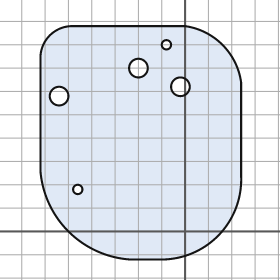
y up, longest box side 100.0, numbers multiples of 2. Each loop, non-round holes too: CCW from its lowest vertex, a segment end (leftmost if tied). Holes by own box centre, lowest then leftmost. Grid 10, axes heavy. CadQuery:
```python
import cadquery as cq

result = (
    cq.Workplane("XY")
    .moveTo(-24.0, -12.0)
    .lineTo(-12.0, -12.0)
    .threePointArc((14.0, -2.0), (24.0, 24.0))
    .lineTo(24.0, 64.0)
    .threePointArc((16.0, 80.0), (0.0, 88.0))
    .lineTo(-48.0, 88.0)
    .threePointArc((-58.0, 84.0), (-62.0, 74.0))
    .lineTo(-62.0, 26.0)
    .threePointArc((-50.0, 0.0), (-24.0, -12.0))
    .close()
    .moveTo(-46.0, 18.0)
    .circle(2.0)
    .moveTo(-54.0, 58.0)
    .circle(4.0)
    .moveTo(-2.0, 62.0)
    .circle(4.0)
    .moveTo(-20.0, 70.0)
    .circle(4.0)
    .moveTo(-8.0, 80.0)
    .circle(2.0)
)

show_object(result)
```